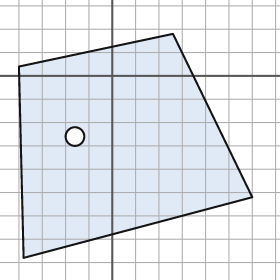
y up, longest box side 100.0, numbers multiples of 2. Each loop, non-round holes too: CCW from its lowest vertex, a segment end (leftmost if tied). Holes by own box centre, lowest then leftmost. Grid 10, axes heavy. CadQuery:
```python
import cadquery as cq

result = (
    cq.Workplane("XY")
    .moveTo(-38.0, -78.0)
    .lineTo(60.0, -52.0)
    .lineTo(26.0, 18.0)
    .lineTo(-40.0, 4.0)
    .close()
    .moveTo(-16.0, -26.0)
    .circle(4.0)
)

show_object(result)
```